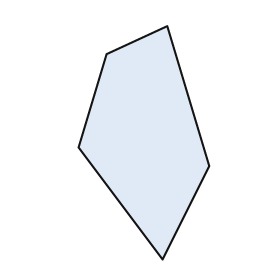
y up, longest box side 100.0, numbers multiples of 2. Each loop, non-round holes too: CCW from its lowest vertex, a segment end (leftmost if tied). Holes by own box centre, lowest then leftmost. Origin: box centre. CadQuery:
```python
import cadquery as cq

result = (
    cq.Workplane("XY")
    .moveTo(8.0, -50.0)
    .lineTo(28.0, -10.0)
    .lineTo(10.0, 50.0)
    .lineTo(-16.0, 38.0)
    .lineTo(-28.0, -2.0)
    .close()
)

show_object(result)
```